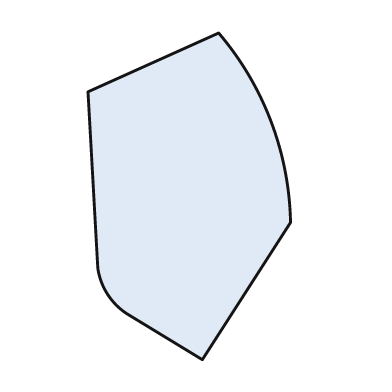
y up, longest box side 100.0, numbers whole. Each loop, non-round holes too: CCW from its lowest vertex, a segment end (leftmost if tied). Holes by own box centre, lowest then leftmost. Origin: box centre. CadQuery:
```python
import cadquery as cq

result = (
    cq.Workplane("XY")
    .moveTo(4.0, -50.0)
    .lineTo(31.0, -8.0)
    .threePointArc((25.0, 23.0), (9.0, 50.0))
    .lineTo(-31.0, 32.0)
    .lineTo(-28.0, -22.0)
    .threePointArc((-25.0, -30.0), (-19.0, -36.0))
    .close()
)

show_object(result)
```